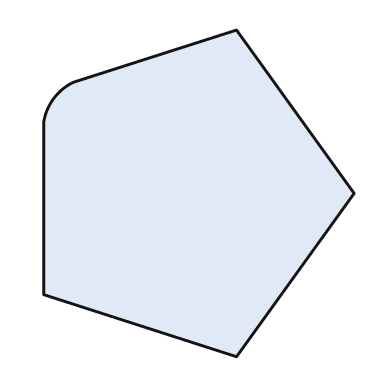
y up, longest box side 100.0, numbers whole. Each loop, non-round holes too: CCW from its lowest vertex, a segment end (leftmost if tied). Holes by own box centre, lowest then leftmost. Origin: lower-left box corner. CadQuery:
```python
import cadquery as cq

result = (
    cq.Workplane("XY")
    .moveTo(59.0, 0.0)
    .lineTo(95.0, 50.0)
    .lineTo(59.0, 100.0)
    .lineTo(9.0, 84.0)
    .threePointArc((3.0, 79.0), (0.0, 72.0))
    .lineTo(0.0, 19.0)
    .close()
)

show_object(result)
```